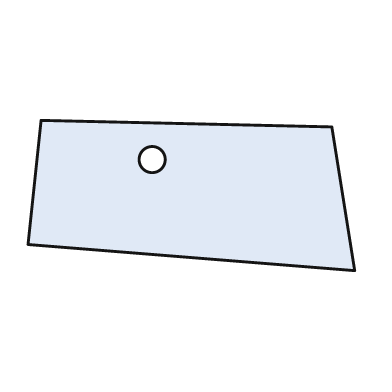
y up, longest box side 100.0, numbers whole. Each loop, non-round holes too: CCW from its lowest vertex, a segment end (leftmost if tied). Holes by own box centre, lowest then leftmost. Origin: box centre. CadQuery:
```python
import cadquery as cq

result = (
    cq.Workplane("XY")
    .moveTo(50.0, -23.0)
    .lineTo(43.0, 21.0)
    .lineTo(-46.0, 23.0)
    .lineTo(-50.0, -15.0)
    .close()
    .moveTo(-12.0, 11.0)
    .circle(4.0)
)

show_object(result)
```